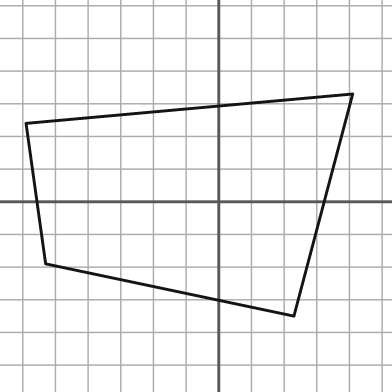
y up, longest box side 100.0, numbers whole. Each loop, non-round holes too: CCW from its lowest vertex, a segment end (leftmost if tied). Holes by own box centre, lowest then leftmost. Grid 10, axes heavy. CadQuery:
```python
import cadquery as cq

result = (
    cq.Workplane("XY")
    .moveTo(23.0, -35.0)
    .lineTo(41.0, 33.0)
    .lineTo(-59.0, 24.0)
    .lineTo(-53.0, -19.0)
    .close()
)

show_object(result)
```